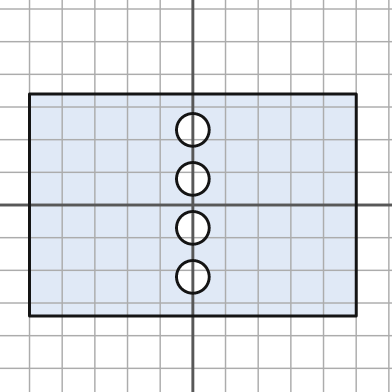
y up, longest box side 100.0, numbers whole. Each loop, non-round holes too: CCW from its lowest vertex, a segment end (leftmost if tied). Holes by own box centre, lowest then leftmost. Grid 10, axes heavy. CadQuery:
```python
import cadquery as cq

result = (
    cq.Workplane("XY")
    .moveTo(-50.0, -34.0)
    .lineTo(50.0, -34.0)
    .lineTo(50.0, 34.0)
    .lineTo(-50.0, 34.0)
    .close()
    .moveTo(0.0, -22.0)
    .circle(5.0)
    .moveTo(0.0, -7.0)
    .circle(5.0)
    .moveTo(0.0, 8.0)
    .circle(5.0)
    .moveTo(0.0, 23.0)
    .circle(5.0)
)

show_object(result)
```